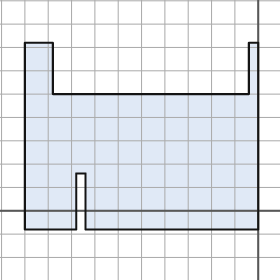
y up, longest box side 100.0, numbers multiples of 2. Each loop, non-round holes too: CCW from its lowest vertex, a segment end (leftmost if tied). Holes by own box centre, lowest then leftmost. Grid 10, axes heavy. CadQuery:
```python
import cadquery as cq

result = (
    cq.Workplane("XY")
    .moveTo(-100.0, -8.0)
    .lineTo(-78.0, -8.0)
    .lineTo(-78.0, 16.0)
    .lineTo(-74.0, 16.0)
    .lineTo(-74.0, -8.0)
    .lineTo(0.0, -8.0)
    .lineTo(0.0, 72.0)
    .lineTo(-4.0, 72.0)
    .lineTo(-4.0, 50.0)
    .lineTo(-88.0, 50.0)
    .lineTo(-88.0, 72.0)
    .lineTo(-100.0, 72.0)
    .close()
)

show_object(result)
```